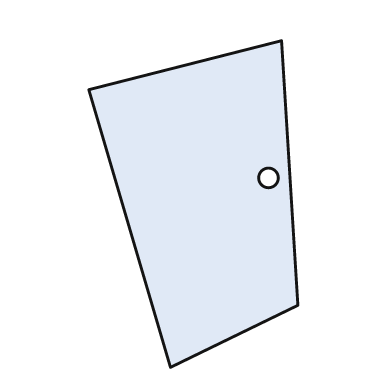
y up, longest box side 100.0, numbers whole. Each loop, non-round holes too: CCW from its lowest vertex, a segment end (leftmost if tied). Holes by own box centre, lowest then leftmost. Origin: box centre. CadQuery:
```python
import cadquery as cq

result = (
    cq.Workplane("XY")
    .moveTo(-7.0, -50.0)
    .lineTo(32.0, -31.0)
    .lineTo(27.0, 50.0)
    .lineTo(-32.0, 35.0)
    .close()
    .moveTo(23.0, 8.0)
    .circle(3.0)
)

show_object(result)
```